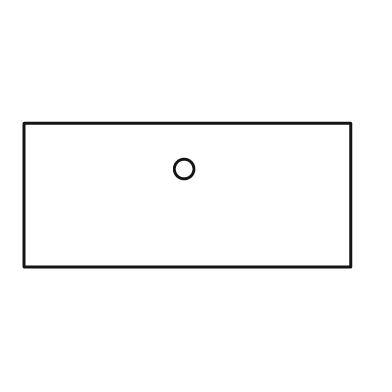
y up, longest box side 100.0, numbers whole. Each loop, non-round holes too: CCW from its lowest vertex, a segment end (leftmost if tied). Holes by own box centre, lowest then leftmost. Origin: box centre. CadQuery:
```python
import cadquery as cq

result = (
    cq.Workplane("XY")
    .moveTo(-50.0, -22.0)
    .lineTo(50.0, -22.0)
    .lineTo(50.0, 22.0)
    .lineTo(-50.0, 22.0)
    .close()
    .moveTo(-1.0, 8.0)
    .circle(3.0)
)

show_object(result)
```